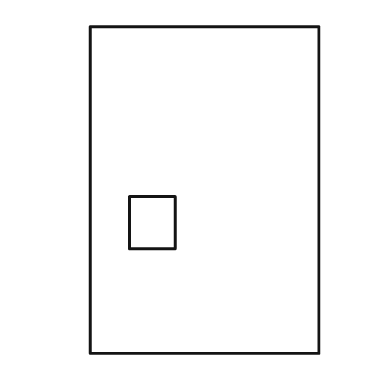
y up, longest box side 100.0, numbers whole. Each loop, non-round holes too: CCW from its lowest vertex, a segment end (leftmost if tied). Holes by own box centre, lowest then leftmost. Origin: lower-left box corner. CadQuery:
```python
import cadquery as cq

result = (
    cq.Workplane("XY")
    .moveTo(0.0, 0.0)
    .lineTo(70.0, 0.0)
    .lineTo(70.0, 100.0)
    .lineTo(0.0, 100.0)
    .close()
    .moveTo(12.0, 32.0)
    .lineTo(26.0, 32.0)
    .lineTo(26.0, 48.0)
    .lineTo(12.0, 48.0)
    .close()
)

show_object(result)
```